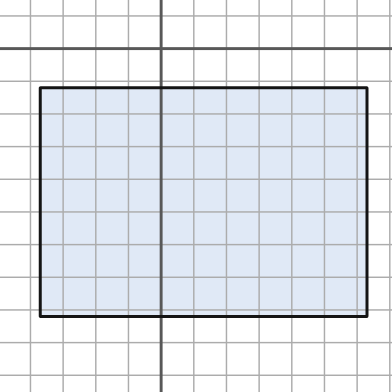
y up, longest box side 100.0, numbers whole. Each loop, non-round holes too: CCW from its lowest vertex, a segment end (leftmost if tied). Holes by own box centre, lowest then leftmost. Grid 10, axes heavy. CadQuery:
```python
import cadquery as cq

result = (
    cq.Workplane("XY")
    .moveTo(-37.0, -82.0)
    .lineTo(63.0, -82.0)
    .lineTo(63.0, -12.0)
    .lineTo(-37.0, -12.0)
    .close()
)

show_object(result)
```